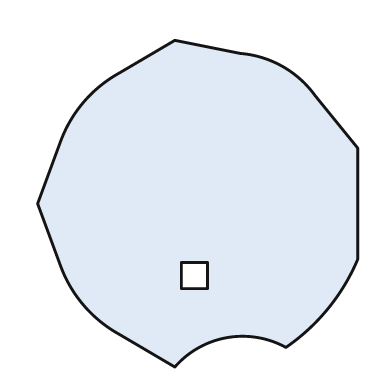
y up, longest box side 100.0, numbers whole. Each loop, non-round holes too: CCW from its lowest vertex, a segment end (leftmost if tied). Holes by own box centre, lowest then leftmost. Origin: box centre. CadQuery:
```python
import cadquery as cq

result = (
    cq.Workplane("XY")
    .moveTo(-7.0, -50.0)
    .threePointArc((9.0, -41.0), (27.0, -44.0))
    .threePointArc((40.0, -32.0), (49.0, -17.0))
    .lineTo(49.0, 17.0)
    .lineTo(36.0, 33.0)
    .threePointArc((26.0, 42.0), (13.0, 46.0))
    .lineTo(-7.0, 50.0)
    .lineTo(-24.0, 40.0)
    .threePointArc((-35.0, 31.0), (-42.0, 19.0))
    .lineTo(-49.0, 0.0)
    .lineTo(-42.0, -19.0)
    .threePointArc((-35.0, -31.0), (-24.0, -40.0))
    .close()
    .moveTo(-5.0, -26.0)
    .lineTo(3.0, -26.0)
    .lineTo(3.0, -18.0)
    .lineTo(-5.0, -18.0)
    .close()
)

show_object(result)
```